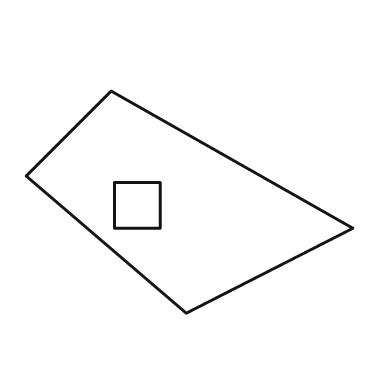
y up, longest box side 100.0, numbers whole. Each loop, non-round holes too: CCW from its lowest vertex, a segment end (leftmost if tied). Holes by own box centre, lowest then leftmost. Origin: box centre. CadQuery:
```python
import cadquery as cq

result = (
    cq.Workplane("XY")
    .moveTo(-1.0, -34.0)
    .lineTo(50.0, -8.0)
    .lineTo(-24.0, 34.0)
    .lineTo(-50.0, 8.0)
    .close()
    .moveTo(-23.0, -8.0)
    .lineTo(-9.0, -8.0)
    .lineTo(-9.0, 6.0)
    .lineTo(-23.0, 6.0)
    .close()
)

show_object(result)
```